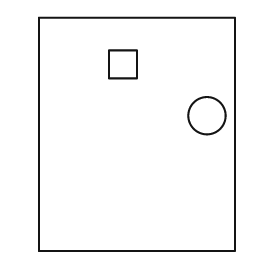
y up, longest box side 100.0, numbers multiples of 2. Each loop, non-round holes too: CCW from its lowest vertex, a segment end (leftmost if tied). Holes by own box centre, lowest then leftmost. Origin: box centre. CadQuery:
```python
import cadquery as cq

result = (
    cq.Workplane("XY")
    .moveTo(-42.0, -50.0)
    .lineTo(42.0, -50.0)
    .lineTo(42.0, 50.0)
    .lineTo(-42.0, 50.0)
    .close()
    .moveTo(30.0, 8.0)
    .circle(8.0)
    .moveTo(-12.0, 24.0)
    .lineTo(0.0, 24.0)
    .lineTo(0.0, 36.0)
    .lineTo(-12.0, 36.0)
    .close()
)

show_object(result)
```